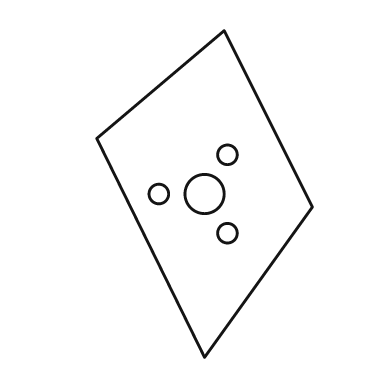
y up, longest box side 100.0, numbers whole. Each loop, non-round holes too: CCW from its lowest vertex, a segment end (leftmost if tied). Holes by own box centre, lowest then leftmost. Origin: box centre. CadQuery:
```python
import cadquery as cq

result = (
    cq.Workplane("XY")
    .moveTo(0.0, -50.0)
    .lineTo(33.0, -4.0)
    .lineTo(6.0, 50.0)
    .lineTo(-33.0, 17.0)
    .close()
    .moveTo(7.0, -12.0)
    .circle(3.0)
    .moveTo(-14.0, 0.0)
    .circle(3.0)
    .moveTo(0.0, 0.0)
    .circle(6.0)
    .moveTo(7.0, 12.0)
    .circle(3.0)
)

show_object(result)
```